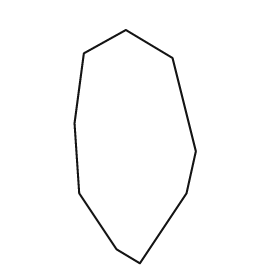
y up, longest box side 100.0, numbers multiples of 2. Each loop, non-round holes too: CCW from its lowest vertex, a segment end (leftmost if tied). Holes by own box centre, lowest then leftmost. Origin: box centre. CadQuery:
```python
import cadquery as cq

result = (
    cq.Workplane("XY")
    .moveTo(2.0, -50.0)
    .lineTo(22.0, -20.0)
    .lineTo(26.0, -2.0)
    .lineTo(16.0, 38.0)
    .lineTo(-4.0, 50.0)
    .lineTo(-22.0, 40.0)
    .lineTo(-26.0, 10.0)
    .lineTo(-24.0, -20.0)
    .lineTo(-8.0, -44.0)
    .close()
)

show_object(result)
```